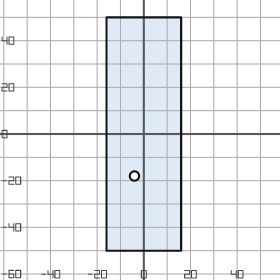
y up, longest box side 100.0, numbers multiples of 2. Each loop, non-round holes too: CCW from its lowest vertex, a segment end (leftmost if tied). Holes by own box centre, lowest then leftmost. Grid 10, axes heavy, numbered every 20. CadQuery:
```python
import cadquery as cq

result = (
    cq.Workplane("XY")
    .moveTo(-16.0, -50.0)
    .lineTo(16.0, -50.0)
    .lineTo(16.0, 50.0)
    .lineTo(-16.0, 50.0)
    .close()
    .moveTo(-4.0, -18.0)
    .circle(2.0)
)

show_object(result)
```